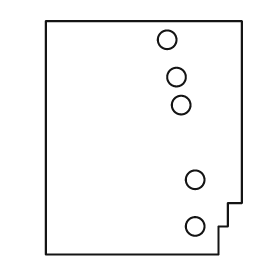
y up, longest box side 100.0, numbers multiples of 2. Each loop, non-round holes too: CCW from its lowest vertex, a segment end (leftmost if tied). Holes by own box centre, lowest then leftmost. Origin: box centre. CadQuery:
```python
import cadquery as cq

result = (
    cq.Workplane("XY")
    .moveTo(-42.0, -50.0)
    .lineTo(32.0, -50.0)
    .lineTo(32.0, -38.0)
    .lineTo(36.0, -38.0)
    .lineTo(36.0, -28.0)
    .lineTo(42.0, -28.0)
    .lineTo(42.0, 50.0)
    .lineTo(-42.0, 50.0)
    .close()
    .moveTo(22.0, -38.0)
    .circle(4.0)
    .moveTo(22.0, -18.0)
    .circle(4.0)
    .moveTo(16.0, 14.0)
    .circle(4.0)
    .moveTo(14.0, 26.0)
    .circle(4.0)
    .moveTo(10.0, 42.0)
    .circle(4.0)
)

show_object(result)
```